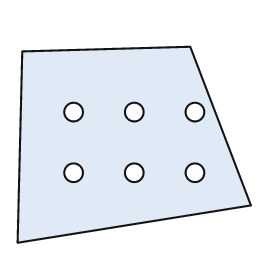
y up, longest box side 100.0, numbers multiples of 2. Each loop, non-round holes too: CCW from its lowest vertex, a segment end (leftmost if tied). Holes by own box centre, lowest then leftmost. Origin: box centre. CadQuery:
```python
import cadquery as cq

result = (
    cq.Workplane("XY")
    .moveTo(-50.0, -42.0)
    .lineTo(50.0, -26.0)
    .lineTo(24.0, 42.0)
    .lineTo(-48.0, 40.0)
    .close()
    .moveTo(-26.0, -12.0)
    .circle(4.0)
    .moveTo(0.0, -12.0)
    .circle(4.0)
    .moveTo(26.0, -12.0)
    .circle(4.0)
    .moveTo(-26.0, 14.0)
    .circle(4.0)
    .moveTo(0.0, 14.0)
    .circle(4.0)
    .moveTo(26.0, 14.0)
    .circle(4.0)
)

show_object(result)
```